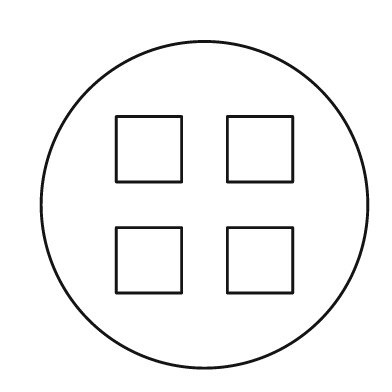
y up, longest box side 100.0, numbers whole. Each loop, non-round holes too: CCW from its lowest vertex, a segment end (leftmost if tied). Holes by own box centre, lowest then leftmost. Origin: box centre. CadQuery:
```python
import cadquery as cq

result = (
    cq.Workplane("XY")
    .moveTo(0.0, 0.0)
    .circle(50.0)
    .moveTo(-27.0, -27.0)
    .lineTo(-7.0, -27.0)
    .lineTo(-7.0, -7.0)
    .lineTo(-27.0, -7.0)
    .close()
    .moveTo(7.0, -27.0)
    .lineTo(27.0, -27.0)
    .lineTo(27.0, -7.0)
    .lineTo(7.0, -7.0)
    .close()
    .moveTo(-27.0, 7.0)
    .lineTo(-7.0, 7.0)
    .lineTo(-7.0, 27.0)
    .lineTo(-27.0, 27.0)
    .close()
    .moveTo(7.0, 7.0)
    .lineTo(27.0, 7.0)
    .lineTo(27.0, 27.0)
    .lineTo(7.0, 27.0)
    .close()
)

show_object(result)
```